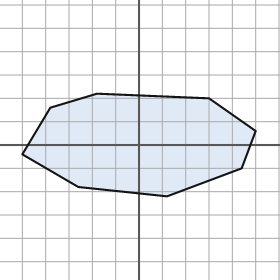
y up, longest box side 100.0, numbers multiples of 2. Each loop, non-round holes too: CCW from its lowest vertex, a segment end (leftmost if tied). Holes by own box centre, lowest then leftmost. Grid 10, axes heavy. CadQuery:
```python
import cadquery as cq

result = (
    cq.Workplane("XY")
    .moveTo(12.0, -22.0)
    .lineTo(44.0, -10.0)
    .lineTo(50.0, 6.0)
    .lineTo(30.0, 20.0)
    .lineTo(-18.0, 22.0)
    .lineTo(-38.0, 16.0)
    .lineTo(-50.0, -4.0)
    .lineTo(-26.0, -18.0)
    .close()
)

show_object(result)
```